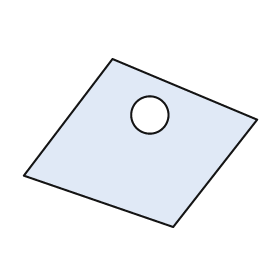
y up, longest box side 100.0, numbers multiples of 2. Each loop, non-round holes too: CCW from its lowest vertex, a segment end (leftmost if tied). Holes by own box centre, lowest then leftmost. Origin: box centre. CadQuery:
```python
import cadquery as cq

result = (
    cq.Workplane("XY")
    .moveTo(14.0, -36.0)
    .lineTo(50.0, 10.0)
    .lineTo(-12.0, 36.0)
    .lineTo(-50.0, -14.0)
    .close()
    .moveTo(4.0, 12.0)
    .circle(8.0)
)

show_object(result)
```